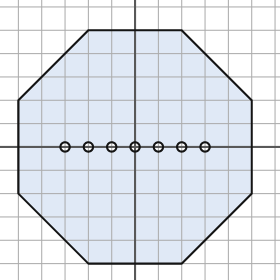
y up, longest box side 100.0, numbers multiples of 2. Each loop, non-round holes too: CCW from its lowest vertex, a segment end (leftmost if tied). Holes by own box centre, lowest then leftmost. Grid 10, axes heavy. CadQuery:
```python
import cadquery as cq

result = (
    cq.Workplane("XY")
    .moveTo(-20.0, -50.0)
    .lineTo(20.0, -50.0)
    .lineTo(50.0, -20.0)
    .lineTo(50.0, 20.0)
    .lineTo(20.0, 50.0)
    .lineTo(-20.0, 50.0)
    .lineTo(-50.0, 20.0)
    .lineTo(-50.0, -20.0)
    .close()
    .moveTo(-30.0, 0.0)
    .circle(2.0)
    .moveTo(-20.0, 0.0)
    .circle(2.0)
    .moveTo(-10.0, 0.0)
    .circle(2.0)
    .moveTo(0.0, 0.0)
    .circle(2.0)
    .moveTo(10.0, 0.0)
    .circle(2.0)
    .moveTo(20.0, 0.0)
    .circle(2.0)
    .moveTo(30.0, 0.0)
    .circle(2.0)
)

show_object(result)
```